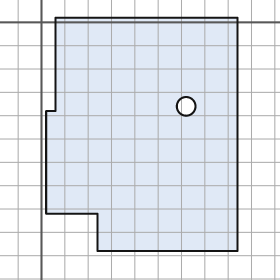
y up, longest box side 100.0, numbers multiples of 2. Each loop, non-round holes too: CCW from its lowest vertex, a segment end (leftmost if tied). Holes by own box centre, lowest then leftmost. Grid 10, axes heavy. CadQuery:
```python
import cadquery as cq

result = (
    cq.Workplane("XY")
    .moveTo(24.0, -98.0)
    .lineTo(84.0, -98.0)
    .lineTo(84.0, 2.0)
    .lineTo(6.0, 2.0)
    .lineTo(6.0, -38.0)
    .lineTo(2.0, -38.0)
    .lineTo(2.0, -82.0)
    .lineTo(24.0, -82.0)
    .close()
    .moveTo(62.0, -36.0)
    .circle(4.0)
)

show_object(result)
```